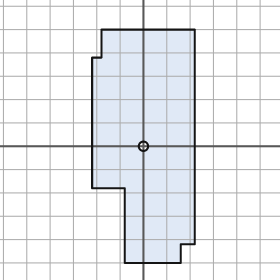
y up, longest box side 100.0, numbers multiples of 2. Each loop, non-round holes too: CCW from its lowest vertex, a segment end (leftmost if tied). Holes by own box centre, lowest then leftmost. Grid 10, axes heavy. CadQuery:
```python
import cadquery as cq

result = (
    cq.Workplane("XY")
    .moveTo(-8.0, -50.0)
    .lineTo(16.0, -50.0)
    .lineTo(16.0, -42.0)
    .lineTo(22.0, -42.0)
    .lineTo(22.0, 50.0)
    .lineTo(-18.0, 50.0)
    .lineTo(-18.0, 38.0)
    .lineTo(-22.0, 38.0)
    .lineTo(-22.0, -18.0)
    .lineTo(-8.0, -18.0)
    .close()
    .moveTo(0.0, 0.0)
    .circle(2.0)
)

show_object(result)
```